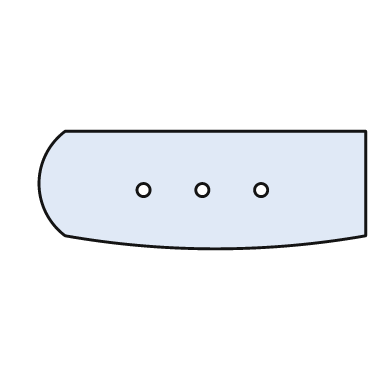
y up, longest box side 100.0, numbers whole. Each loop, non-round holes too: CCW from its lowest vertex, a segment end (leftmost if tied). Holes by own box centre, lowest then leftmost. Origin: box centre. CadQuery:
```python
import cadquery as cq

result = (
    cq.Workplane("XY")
    .moveTo(-42.0, -14.0)
    .threePointArc((4.0, -18.0), (50.0, -14.0))
    .lineTo(50.0, 18.0)
    .lineTo(-42.0, 18.0)
    .threePointArc((-50.0, 2.0), (-42.0, -14.0))
    .close()
    .moveTo(-18.0, 0.0)
    .circle(2.0)
    .moveTo(0.0, 0.0)
    .circle(2.0)
    .moveTo(18.0, 0.0)
    .circle(2.0)
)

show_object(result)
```